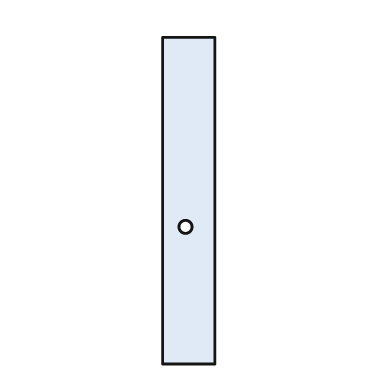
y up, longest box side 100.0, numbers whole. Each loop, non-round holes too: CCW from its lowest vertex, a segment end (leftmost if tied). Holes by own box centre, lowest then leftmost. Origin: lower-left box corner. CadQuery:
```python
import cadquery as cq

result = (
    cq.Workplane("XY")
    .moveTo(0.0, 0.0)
    .lineTo(16.0, 0.0)
    .lineTo(16.0, 100.0)
    .lineTo(0.0, 100.0)
    .close()
    .moveTo(7.0, 42.0)
    .circle(2.0)
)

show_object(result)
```